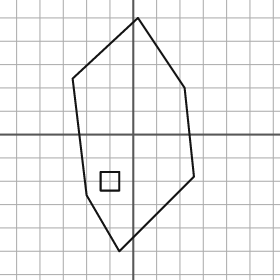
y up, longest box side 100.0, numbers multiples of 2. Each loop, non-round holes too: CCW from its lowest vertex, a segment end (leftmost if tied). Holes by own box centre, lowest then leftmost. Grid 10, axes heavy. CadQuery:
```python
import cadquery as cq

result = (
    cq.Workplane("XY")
    .moveTo(-6.0, -50.0)
    .lineTo(26.0, -18.0)
    .lineTo(22.0, 20.0)
    .lineTo(2.0, 50.0)
    .lineTo(-26.0, 24.0)
    .lineTo(-20.0, -26.0)
    .close()
    .moveTo(-14.0, -24.0)
    .lineTo(-6.0, -24.0)
    .lineTo(-6.0, -16.0)
    .lineTo(-14.0, -16.0)
    .close()
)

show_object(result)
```